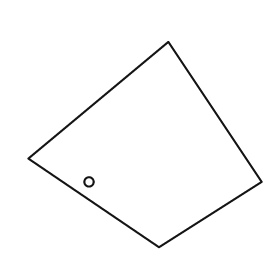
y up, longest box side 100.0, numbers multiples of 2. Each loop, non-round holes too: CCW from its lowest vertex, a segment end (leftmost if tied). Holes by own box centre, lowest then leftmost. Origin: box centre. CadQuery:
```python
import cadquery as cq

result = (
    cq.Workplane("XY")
    .moveTo(6.0, -44.0)
    .lineTo(50.0, -16.0)
    .lineTo(10.0, 44.0)
    .lineTo(-50.0, -6.0)
    .close()
    .moveTo(-24.0, -16.0)
    .circle(2.0)
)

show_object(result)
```